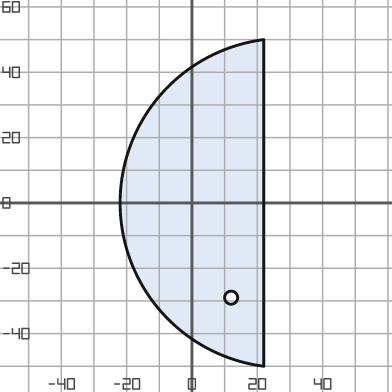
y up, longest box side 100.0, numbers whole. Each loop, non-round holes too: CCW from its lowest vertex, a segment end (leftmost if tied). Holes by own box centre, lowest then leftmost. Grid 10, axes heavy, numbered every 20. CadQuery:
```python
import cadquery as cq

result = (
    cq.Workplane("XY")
    .moveTo(22.0, -50.0)
    .lineTo(22.0, 50.0)
    .threePointArc((-22.0, 0.0), (22.0, -50.0))
    .close()
    .moveTo(12.0, -29.0)
    .circle(2.0)
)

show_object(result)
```